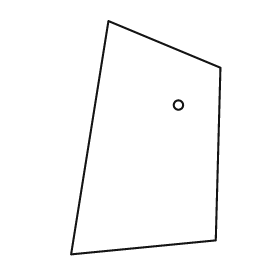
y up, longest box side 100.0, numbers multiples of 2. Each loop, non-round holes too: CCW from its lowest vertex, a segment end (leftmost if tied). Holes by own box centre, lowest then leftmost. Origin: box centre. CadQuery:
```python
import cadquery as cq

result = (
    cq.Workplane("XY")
    .moveTo(-32.0, -50.0)
    .lineTo(30.0, -44.0)
    .lineTo(32.0, 30.0)
    .lineTo(-16.0, 50.0)
    .close()
    .moveTo(14.0, 14.0)
    .circle(2.0)
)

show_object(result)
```